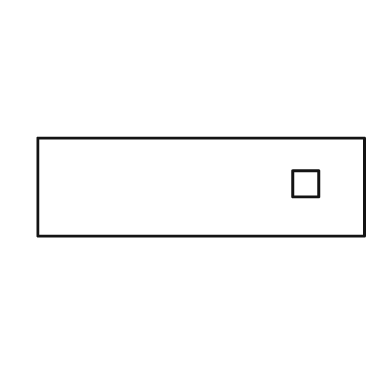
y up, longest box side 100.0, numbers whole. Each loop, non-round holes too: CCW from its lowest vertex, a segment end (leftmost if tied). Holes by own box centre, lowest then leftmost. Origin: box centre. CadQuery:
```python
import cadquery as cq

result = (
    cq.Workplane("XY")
    .moveTo(-50.0, -15.0)
    .lineTo(50.0, -15.0)
    .lineTo(50.0, 15.0)
    .lineTo(-50.0, 15.0)
    .close()
    .moveTo(28.0, -3.0)
    .lineTo(36.0, -3.0)
    .lineTo(36.0, 5.0)
    .lineTo(28.0, 5.0)
    .close()
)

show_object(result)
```